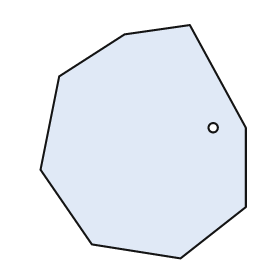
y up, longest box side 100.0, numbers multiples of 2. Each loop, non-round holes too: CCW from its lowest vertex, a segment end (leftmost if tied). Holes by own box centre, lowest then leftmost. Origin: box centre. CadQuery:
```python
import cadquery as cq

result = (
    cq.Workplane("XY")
    .moveTo(16.0, -50.0)
    .lineTo(44.0, -28.0)
    .lineTo(44.0, 6.0)
    .lineTo(20.0, 50.0)
    .lineTo(-8.0, 46.0)
    .lineTo(-36.0, 28.0)
    .lineTo(-44.0, -12.0)
    .lineTo(-22.0, -44.0)
    .close()
    .moveTo(30.0, 6.0)
    .circle(2.0)
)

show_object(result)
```